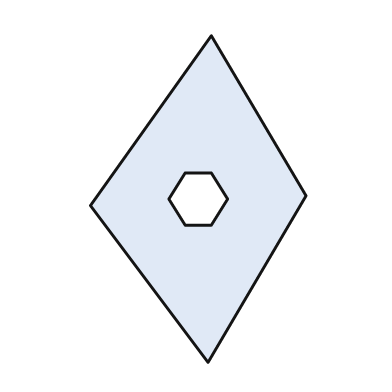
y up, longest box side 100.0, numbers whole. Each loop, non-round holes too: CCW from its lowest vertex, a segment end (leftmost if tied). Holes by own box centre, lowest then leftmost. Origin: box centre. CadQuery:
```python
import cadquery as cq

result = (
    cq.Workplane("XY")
    .moveTo(3.0, -50.0)
    .lineTo(33.0, 1.0)
    .lineTo(4.0, 50.0)
    .lineTo(-33.0, -2.0)
    .close()
    .moveTo(-4.0, -8.0)
    .lineTo(4.0, -8.0)
    .lineTo(9.0, 0.0)
    .lineTo(4.0, 8.0)
    .lineTo(-4.0, 8.0)
    .lineTo(-9.0, 0.0)
    .close()
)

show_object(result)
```